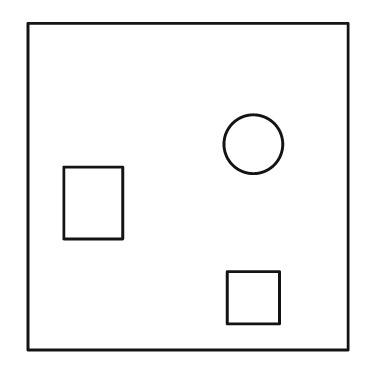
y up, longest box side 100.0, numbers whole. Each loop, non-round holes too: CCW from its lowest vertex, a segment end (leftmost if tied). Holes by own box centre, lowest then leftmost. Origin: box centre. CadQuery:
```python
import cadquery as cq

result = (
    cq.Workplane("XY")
    .moveTo(-49.0, -50.0)
    .lineTo(49.0, -50.0)
    .lineTo(49.0, 50.0)
    .lineTo(-49.0, 50.0)
    .close()
    .moveTo(12.0, -42.0)
    .lineTo(28.0, -42.0)
    .lineTo(28.0, -26.0)
    .lineTo(12.0, -26.0)
    .close()
    .moveTo(-38.0, -16.0)
    .lineTo(-20.0, -16.0)
    .lineTo(-20.0, 6.0)
    .lineTo(-38.0, 6.0)
    .close()
    .moveTo(20.0, 13.0)
    .circle(9.0)
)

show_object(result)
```